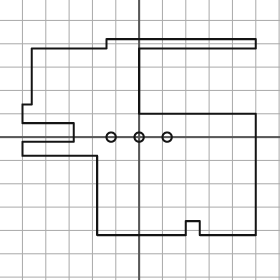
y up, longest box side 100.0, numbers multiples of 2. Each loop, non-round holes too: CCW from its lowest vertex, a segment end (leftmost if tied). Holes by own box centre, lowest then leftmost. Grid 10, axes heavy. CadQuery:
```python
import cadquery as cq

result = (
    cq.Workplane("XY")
    .moveTo(-18.0, -42.0)
    .lineTo(20.0, -42.0)
    .lineTo(20.0, -36.0)
    .lineTo(26.0, -36.0)
    .lineTo(26.0, -42.0)
    .lineTo(50.0, -42.0)
    .lineTo(50.0, 10.0)
    .lineTo(0.0, 10.0)
    .lineTo(0.0, 38.0)
    .lineTo(50.0, 38.0)
    .lineTo(50.0, 42.0)
    .lineTo(-14.0, 42.0)
    .lineTo(-14.0, 38.0)
    .lineTo(-46.0, 38.0)
    .lineTo(-46.0, 14.0)
    .lineTo(-50.0, 14.0)
    .lineTo(-50.0, 6.0)
    .lineTo(-28.0, 6.0)
    .lineTo(-28.0, -2.0)
    .lineTo(-50.0, -2.0)
    .lineTo(-50.0, -8.0)
    .lineTo(-18.0, -8.0)
    .close()
    .moveTo(-12.0, 0.0)
    .circle(2.0)
    .moveTo(0.0, 0.0)
    .circle(2.0)
    .moveTo(12.0, 0.0)
    .circle(2.0)
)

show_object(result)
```